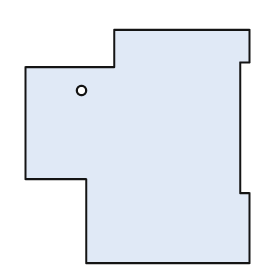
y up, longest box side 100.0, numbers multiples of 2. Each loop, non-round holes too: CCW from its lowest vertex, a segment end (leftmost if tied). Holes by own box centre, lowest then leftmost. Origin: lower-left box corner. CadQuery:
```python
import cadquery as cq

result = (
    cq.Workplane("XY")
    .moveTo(26.0, 0.0)
    .lineTo(96.0, 0.0)
    .lineTo(96.0, 30.0)
    .lineTo(92.0, 30.0)
    .lineTo(92.0, 86.0)
    .lineTo(96.0, 86.0)
    .lineTo(96.0, 100.0)
    .lineTo(38.0, 100.0)
    .lineTo(38.0, 84.0)
    .lineTo(0.0, 84.0)
    .lineTo(0.0, 36.0)
    .lineTo(26.0, 36.0)
    .close()
    .moveTo(24.0, 74.0)
    .circle(2.0)
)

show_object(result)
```